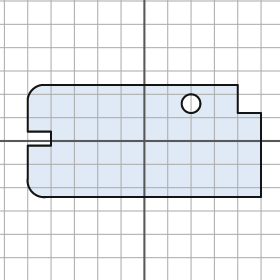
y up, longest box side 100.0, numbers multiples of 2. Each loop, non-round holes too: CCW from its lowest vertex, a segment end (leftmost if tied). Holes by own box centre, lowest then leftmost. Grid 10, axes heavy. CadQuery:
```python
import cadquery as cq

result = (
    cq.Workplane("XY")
    .moveTo(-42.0, -24.0)
    .lineTo(50.0, -24.0)
    .lineTo(50.0, 12.0)
    .lineTo(40.0, 12.0)
    .lineTo(40.0, 24.0)
    .lineTo(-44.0, 24.0)
    .threePointArc((-48.0, 22.0), (-50.0, 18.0))
    .lineTo(-50.0, 4.0)
    .lineTo(-40.0, 4.0)
    .lineTo(-40.0, -2.0)
    .lineTo(-50.0, -2.0)
    .lineTo(-50.0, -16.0)
    .threePointArc((-48.0, -22.0), (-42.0, -24.0))
    .close()
    .moveTo(20.0, 16.0)
    .circle(4.0)
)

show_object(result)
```